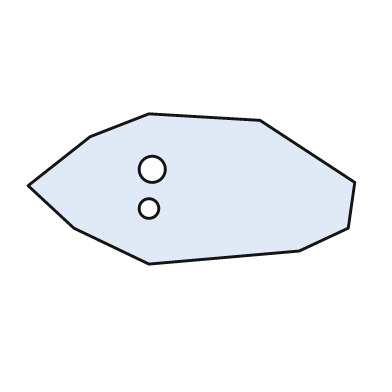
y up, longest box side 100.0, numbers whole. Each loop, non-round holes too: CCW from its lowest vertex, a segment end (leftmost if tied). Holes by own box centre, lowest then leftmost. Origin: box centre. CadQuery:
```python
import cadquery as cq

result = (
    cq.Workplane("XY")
    .moveTo(-13.0, -23.0)
    .lineTo(33.0, -19.0)
    .lineTo(48.0, -12.0)
    .lineTo(50.0, 2.0)
    .lineTo(21.0, 21.0)
    .lineTo(-13.0, 23.0)
    .lineTo(-31.0, 16.0)
    .lineTo(-50.0, 1.0)
    .lineTo(-36.0, -12.0)
    .close()
    .moveTo(-13.0, -6.0)
    .circle(3.0)
    .moveTo(-12.0, 6.0)
    .circle(4.0)
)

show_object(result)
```